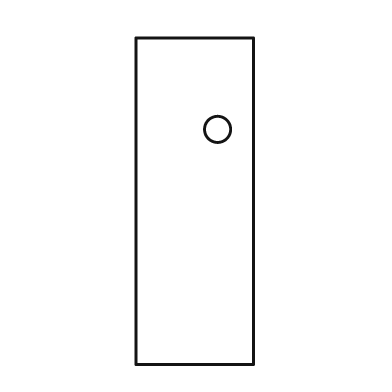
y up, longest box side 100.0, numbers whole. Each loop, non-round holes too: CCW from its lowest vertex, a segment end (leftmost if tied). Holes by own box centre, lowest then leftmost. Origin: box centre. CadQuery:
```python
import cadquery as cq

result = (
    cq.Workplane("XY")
    .moveTo(-18.0, -50.0)
    .lineTo(18.0, -50.0)
    .lineTo(18.0, 50.0)
    .lineTo(-18.0, 50.0)
    .close()
    .moveTo(7.0, 22.0)
    .circle(4.0)
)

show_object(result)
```